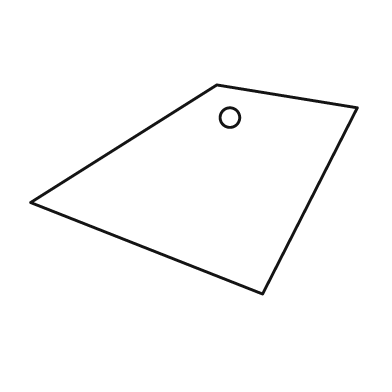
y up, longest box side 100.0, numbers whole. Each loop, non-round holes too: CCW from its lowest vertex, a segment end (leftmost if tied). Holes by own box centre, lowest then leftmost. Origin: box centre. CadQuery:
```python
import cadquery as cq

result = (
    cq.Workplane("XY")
    .moveTo(21.0, -32.0)
    .lineTo(50.0, 25.0)
    .lineTo(7.0, 32.0)
    .lineTo(-50.0, -4.0)
    .close()
    .moveTo(11.0, 22.0)
    .circle(3.0)
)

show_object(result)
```